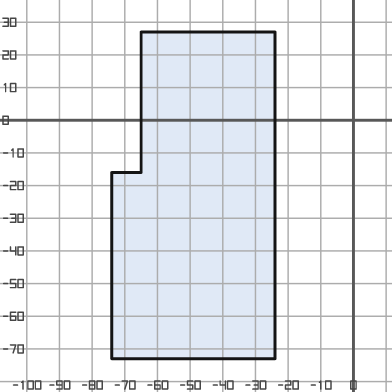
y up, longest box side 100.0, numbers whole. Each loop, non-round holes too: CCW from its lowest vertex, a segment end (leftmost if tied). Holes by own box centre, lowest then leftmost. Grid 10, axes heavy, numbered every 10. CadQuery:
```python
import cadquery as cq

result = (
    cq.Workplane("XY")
    .moveTo(-74.0, -73.0)
    .lineTo(-24.0, -73.0)
    .lineTo(-24.0, 27.0)
    .lineTo(-65.0, 27.0)
    .lineTo(-65.0, -16.0)
    .lineTo(-74.0, -16.0)
    .close()
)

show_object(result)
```